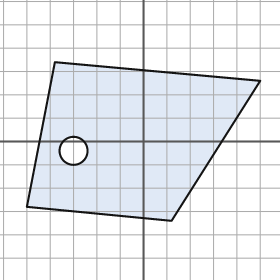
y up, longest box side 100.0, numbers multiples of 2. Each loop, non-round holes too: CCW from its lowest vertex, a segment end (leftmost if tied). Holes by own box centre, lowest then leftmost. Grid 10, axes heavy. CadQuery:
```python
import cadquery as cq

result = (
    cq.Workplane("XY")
    .moveTo(12.0, -34.0)
    .lineTo(50.0, 26.0)
    .lineTo(-38.0, 34.0)
    .lineTo(-50.0, -28.0)
    .close()
    .moveTo(-30.0, -4.0)
    .circle(6.0)
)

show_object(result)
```